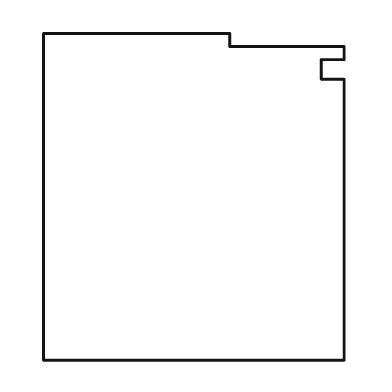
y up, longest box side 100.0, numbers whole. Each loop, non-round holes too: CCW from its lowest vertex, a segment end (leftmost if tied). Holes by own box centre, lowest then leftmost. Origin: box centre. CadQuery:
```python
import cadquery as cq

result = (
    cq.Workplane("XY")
    .moveTo(-46.0, -50.0)
    .lineTo(46.0, -50.0)
    .lineTo(46.0, 36.0)
    .lineTo(39.0, 36.0)
    .lineTo(39.0, 42.0)
    .lineTo(46.0, 42.0)
    .lineTo(46.0, 46.0)
    .lineTo(11.0, 46.0)
    .lineTo(11.0, 50.0)
    .lineTo(-46.0, 50.0)
    .close()
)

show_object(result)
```